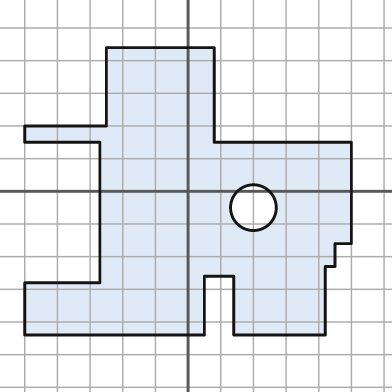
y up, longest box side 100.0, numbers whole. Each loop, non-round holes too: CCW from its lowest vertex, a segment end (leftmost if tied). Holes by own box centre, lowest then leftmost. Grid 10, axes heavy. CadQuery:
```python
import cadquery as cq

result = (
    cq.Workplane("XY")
    .moveTo(-50.0, -44.0)
    .lineTo(5.0, -44.0)
    .lineTo(5.0, -26.0)
    .lineTo(14.0, -26.0)
    .lineTo(14.0, -44.0)
    .lineTo(42.0, -44.0)
    .lineTo(42.0, -23.0)
    .lineTo(45.0, -23.0)
    .lineTo(45.0, -16.0)
    .lineTo(50.0, -16.0)
    .lineTo(50.0, 15.0)
    .lineTo(8.0, 15.0)
    .lineTo(8.0, 44.0)
    .lineTo(-25.0, 44.0)
    .lineTo(-25.0, 20.0)
    .lineTo(-50.0, 20.0)
    .lineTo(-50.0, 15.0)
    .lineTo(-27.0, 15.0)
    .lineTo(-27.0, -28.0)
    .lineTo(-50.0, -28.0)
    .close()
    .moveTo(20.0, -5.0)
    .circle(7.0)
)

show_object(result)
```